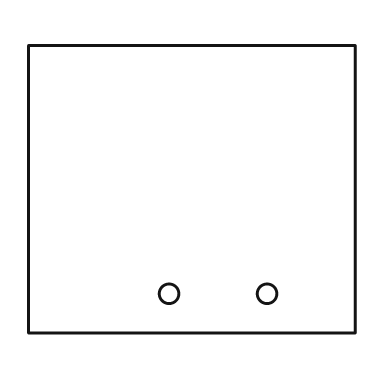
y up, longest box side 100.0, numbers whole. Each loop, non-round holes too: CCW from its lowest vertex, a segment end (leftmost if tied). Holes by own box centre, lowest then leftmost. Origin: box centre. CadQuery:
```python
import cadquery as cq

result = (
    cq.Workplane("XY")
    .moveTo(-50.0, -44.0)
    .lineTo(50.0, -44.0)
    .lineTo(50.0, 44.0)
    .lineTo(-50.0, 44.0)
    .close()
    .moveTo(-7.0, -32.0)
    .circle(3.0)
    .moveTo(23.0, -32.0)
    .circle(3.0)
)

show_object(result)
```